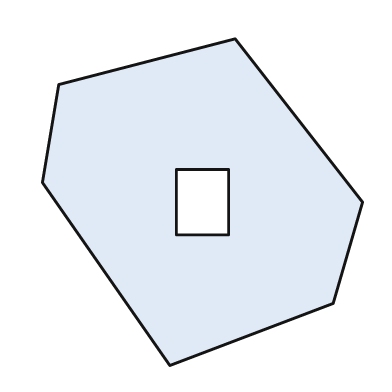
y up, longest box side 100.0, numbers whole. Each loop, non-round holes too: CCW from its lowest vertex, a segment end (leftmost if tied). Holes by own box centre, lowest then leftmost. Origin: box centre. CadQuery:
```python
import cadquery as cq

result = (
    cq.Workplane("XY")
    .moveTo(-10.0, -50.0)
    .lineTo(40.0, -31.0)
    .lineTo(49.0, 0.0)
    .lineTo(10.0, 50.0)
    .lineTo(-44.0, 36.0)
    .lineTo(-49.0, 6.0)
    .close()
    .moveTo(-8.0, -10.0)
    .lineTo(8.0, -10.0)
    .lineTo(8.0, 10.0)
    .lineTo(-8.0, 10.0)
    .close()
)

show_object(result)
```